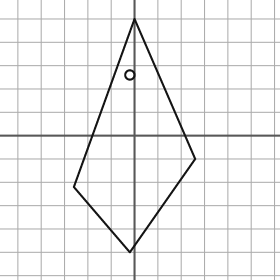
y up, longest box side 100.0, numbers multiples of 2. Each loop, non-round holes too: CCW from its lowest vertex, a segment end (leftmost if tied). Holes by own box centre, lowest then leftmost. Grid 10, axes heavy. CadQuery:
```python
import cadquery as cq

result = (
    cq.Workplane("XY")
    .moveTo(-2.0, -50.0)
    .lineTo(26.0, -10.0)
    .lineTo(0.0, 50.0)
    .lineTo(-26.0, -22.0)
    .close()
    .moveTo(-2.0, 26.0)
    .circle(2.0)
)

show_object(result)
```